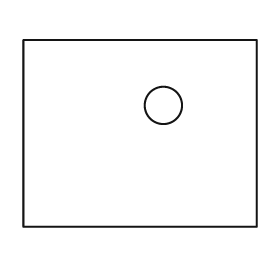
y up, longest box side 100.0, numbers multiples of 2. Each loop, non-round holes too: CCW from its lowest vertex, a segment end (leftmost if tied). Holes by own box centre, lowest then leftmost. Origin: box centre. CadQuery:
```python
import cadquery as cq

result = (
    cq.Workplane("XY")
    .moveTo(-50.0, -40.0)
    .lineTo(50.0, -40.0)
    .lineTo(50.0, 40.0)
    .lineTo(-50.0, 40.0)
    .close()
    .moveTo(10.0, 12.0)
    .circle(8.0)
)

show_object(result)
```